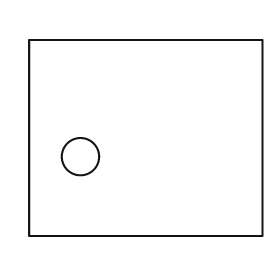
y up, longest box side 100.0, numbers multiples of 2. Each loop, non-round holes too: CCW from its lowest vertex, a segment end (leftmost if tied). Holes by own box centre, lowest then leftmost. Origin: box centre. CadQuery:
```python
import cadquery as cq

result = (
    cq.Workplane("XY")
    .moveTo(-50.0, -42.0)
    .lineTo(50.0, -42.0)
    .lineTo(50.0, 42.0)
    .lineTo(-50.0, 42.0)
    .close()
    .moveTo(-28.0, -8.0)
    .circle(8.0)
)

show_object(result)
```